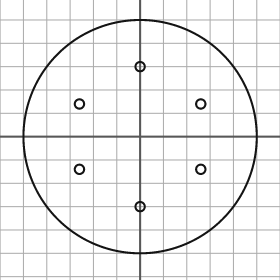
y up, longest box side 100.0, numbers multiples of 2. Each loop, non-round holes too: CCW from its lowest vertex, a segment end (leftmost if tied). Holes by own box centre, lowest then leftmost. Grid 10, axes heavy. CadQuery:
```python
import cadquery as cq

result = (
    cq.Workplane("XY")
    .moveTo(0.0, 0.0)
    .circle(50.0)
    .moveTo(0.0, -30.0)
    .circle(2.0)
    .moveTo(-26.0, -14.0)
    .circle(2.0)
    .moveTo(26.0, -14.0)
    .circle(2.0)
    .moveTo(-26.0, 14.0)
    .circle(2.0)
    .moveTo(26.0, 14.0)
    .circle(2.0)
    .moveTo(0.0, 30.0)
    .circle(2.0)
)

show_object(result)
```